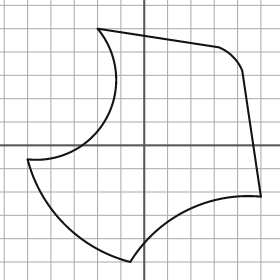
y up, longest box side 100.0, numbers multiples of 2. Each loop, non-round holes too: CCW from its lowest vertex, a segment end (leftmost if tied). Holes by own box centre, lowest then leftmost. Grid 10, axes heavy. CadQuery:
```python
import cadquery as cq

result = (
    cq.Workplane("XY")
    .moveTo(-6.0, -50.0)
    .threePointArc((18.0, -28.0), (50.0, -22.0))
    .lineTo(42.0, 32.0)
    .threePointArc((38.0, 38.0), (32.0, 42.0))
    .lineTo(-20.0, 50.0)
    .threePointArc((-16.0, 12.0), (-50.0, -6.0))
    .threePointArc((-34.0, -34.0), (-6.0, -50.0))
    .close()
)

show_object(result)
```